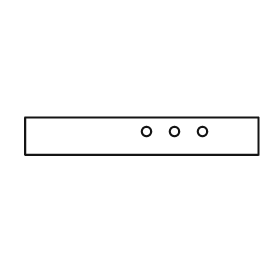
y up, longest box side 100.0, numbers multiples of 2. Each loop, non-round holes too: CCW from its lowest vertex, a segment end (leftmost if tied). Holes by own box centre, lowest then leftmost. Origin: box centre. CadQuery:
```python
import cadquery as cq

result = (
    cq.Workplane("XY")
    .moveTo(-50.0, -8.0)
    .lineTo(50.0, -8.0)
    .lineTo(50.0, 8.0)
    .lineTo(-50.0, 8.0)
    .close()
    .moveTo(2.0, 2.0)
    .circle(2.0)
    .moveTo(14.0, 2.0)
    .circle(2.0)
    .moveTo(26.0, 2.0)
    .circle(2.0)
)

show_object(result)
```